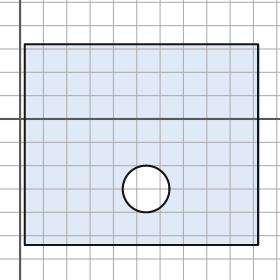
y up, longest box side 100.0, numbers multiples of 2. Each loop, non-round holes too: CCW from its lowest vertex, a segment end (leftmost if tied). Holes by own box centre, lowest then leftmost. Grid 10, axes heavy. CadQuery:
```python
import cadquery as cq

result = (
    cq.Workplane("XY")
    .moveTo(2.0, -54.0)
    .lineTo(102.0, -54.0)
    .lineTo(102.0, 32.0)
    .lineTo(2.0, 32.0)
    .close()
    .moveTo(54.0, -30.0)
    .circle(10.0)
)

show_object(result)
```